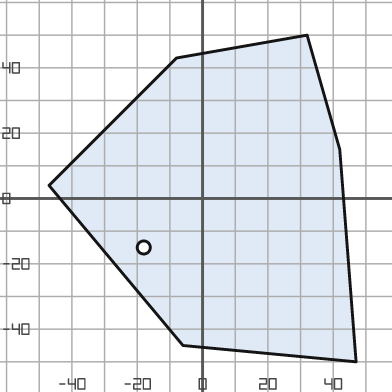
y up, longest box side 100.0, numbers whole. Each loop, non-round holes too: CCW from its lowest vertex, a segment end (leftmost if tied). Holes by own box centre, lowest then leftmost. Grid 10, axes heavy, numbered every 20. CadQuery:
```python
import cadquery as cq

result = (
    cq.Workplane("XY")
    .moveTo(47.0, -50.0)
    .lineTo(42.0, 15.0)
    .lineTo(32.0, 50.0)
    .lineTo(-8.0, 43.0)
    .lineTo(-47.0, 4.0)
    .lineTo(-6.0, -45.0)
    .close()
    .moveTo(-18.0, -15.0)
    .circle(2.0)
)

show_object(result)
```